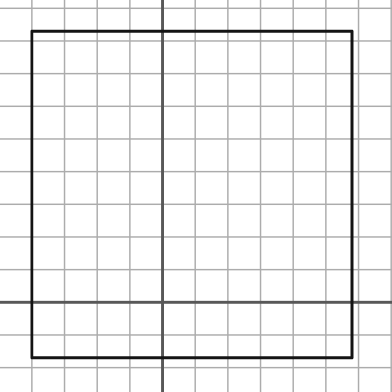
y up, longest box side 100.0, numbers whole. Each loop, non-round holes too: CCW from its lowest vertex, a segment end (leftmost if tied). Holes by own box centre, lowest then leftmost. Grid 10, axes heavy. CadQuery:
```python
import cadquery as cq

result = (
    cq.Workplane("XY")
    .moveTo(-40.0, -17.0)
    .lineTo(58.0, -17.0)
    .lineTo(58.0, 83.0)
    .lineTo(-40.0, 83.0)
    .close()
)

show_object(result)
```